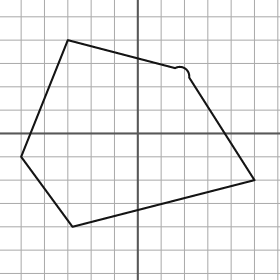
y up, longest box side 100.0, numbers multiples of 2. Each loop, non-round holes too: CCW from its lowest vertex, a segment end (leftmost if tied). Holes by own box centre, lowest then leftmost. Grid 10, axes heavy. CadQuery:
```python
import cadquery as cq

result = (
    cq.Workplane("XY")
    .moveTo(-28.0, -40.0)
    .lineTo(50.0, -20.0)
    .lineTo(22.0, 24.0)
    .threePointArc((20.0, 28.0), (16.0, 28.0))
    .lineTo(-30.0, 40.0)
    .lineTo(-50.0, -10.0)
    .close()
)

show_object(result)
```